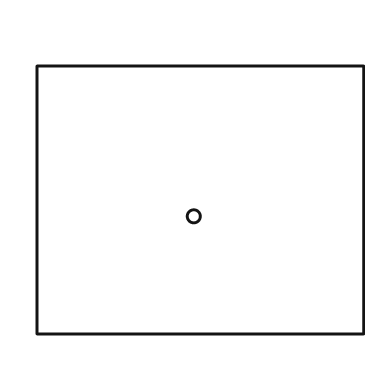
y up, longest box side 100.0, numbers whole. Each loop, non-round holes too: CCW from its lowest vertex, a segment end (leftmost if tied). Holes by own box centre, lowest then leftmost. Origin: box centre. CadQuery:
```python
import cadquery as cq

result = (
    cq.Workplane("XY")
    .moveTo(-50.0, -41.0)
    .lineTo(50.0, -41.0)
    .lineTo(50.0, 41.0)
    .lineTo(-50.0, 41.0)
    .close()
    .moveTo(-2.0, -5.0)
    .circle(2.0)
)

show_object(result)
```